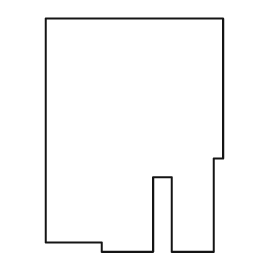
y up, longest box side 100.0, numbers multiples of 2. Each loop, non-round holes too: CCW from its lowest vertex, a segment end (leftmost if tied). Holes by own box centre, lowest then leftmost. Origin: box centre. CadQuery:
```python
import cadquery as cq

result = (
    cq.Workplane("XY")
    .moveTo(-14.0, -50.0)
    .lineTo(8.0, -50.0)
    .lineTo(8.0, -18.0)
    .lineTo(16.0, -18.0)
    .lineTo(16.0, -50.0)
    .lineTo(34.0, -50.0)
    .lineTo(34.0, -10.0)
    .lineTo(38.0, -10.0)
    .lineTo(38.0, 50.0)
    .lineTo(-38.0, 50.0)
    .lineTo(-38.0, -46.0)
    .lineTo(-14.0, -46.0)
    .close()
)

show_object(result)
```